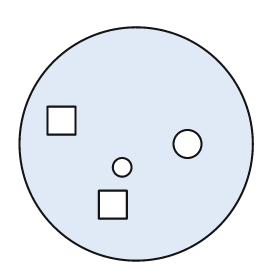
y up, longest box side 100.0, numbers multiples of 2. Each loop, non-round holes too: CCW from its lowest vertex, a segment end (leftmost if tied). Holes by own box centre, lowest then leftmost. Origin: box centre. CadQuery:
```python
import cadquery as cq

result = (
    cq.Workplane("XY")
    .moveTo(0.0, 0.0)
    .circle(50.0)
    .moveTo(-16.0, -32.0)
    .lineTo(-4.0, -32.0)
    .lineTo(-4.0, -20.0)
    .lineTo(-16.0, -20.0)
    .close()
    .moveTo(-6.0, -10.0)
    .circle(4.0)
    .moveTo(22.0, 0.0)
    .circle(6.0)
    .moveTo(-38.0, 4.0)
    .lineTo(-26.0, 4.0)
    .lineTo(-26.0, 16.0)
    .lineTo(-38.0, 16.0)
    .close()
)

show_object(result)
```